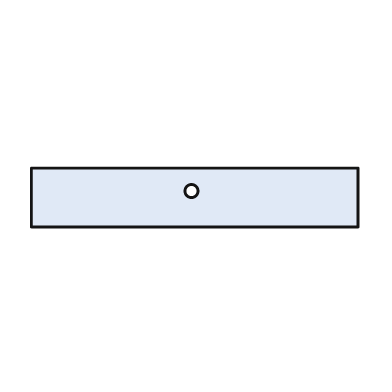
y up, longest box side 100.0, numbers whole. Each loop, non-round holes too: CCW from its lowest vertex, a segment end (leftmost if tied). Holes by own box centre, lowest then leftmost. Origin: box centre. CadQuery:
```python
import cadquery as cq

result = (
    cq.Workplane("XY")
    .moveTo(-50.0, -9.0)
    .lineTo(50.0, -9.0)
    .lineTo(50.0, 9.0)
    .lineTo(-50.0, 9.0)
    .close()
    .moveTo(-1.0, 2.0)
    .circle(2.0)
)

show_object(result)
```